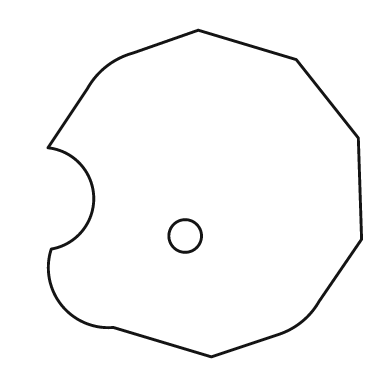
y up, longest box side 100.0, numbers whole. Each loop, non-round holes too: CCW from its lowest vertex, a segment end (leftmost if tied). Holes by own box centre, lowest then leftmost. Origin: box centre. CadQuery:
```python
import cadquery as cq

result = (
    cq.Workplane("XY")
    .moveTo(2.0, -50.0)
    .lineTo(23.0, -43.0)
    .threePointArc((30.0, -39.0), (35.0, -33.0))
    .lineTo(48.0, -14.0)
    .lineTo(47.0, 17.0)
    .lineTo(28.0, 41.0)
    .lineTo(-2.0, 50.0)
    .lineTo(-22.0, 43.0)
    .threePointArc((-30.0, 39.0), (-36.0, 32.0))
    .lineTo(-48.0, 14.0)
    .threePointArc((-34.0, -1.0), (-47.0, -17.0))
    .threePointArc((-44.0, -34.0), (-28.0, -41.0))
    .close()
    .moveTo(-6.0, -13.0)
    .circle(5.0)
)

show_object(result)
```